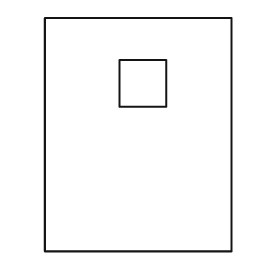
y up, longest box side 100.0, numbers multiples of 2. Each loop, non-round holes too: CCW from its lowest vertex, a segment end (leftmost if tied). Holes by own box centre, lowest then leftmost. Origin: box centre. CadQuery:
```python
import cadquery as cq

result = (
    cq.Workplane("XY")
    .moveTo(-40.0, -50.0)
    .lineTo(40.0, -50.0)
    .lineTo(40.0, 50.0)
    .lineTo(-40.0, 50.0)
    .close()
    .moveTo(-8.0, 12.0)
    .lineTo(12.0, 12.0)
    .lineTo(12.0, 32.0)
    .lineTo(-8.0, 32.0)
    .close()
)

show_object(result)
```